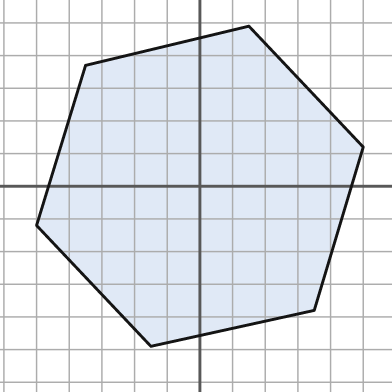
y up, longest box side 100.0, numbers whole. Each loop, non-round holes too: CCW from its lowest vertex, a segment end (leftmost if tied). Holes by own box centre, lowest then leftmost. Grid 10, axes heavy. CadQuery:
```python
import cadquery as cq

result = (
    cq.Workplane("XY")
    .moveTo(-15.0, -49.0)
    .lineTo(35.0, -38.0)
    .lineTo(50.0, 12.0)
    .lineTo(15.0, 49.0)
    .lineTo(-35.0, 37.0)
    .lineTo(-50.0, -12.0)
    .close()
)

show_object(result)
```